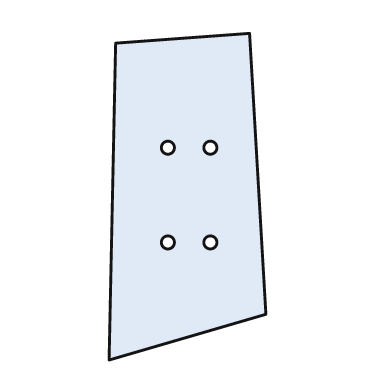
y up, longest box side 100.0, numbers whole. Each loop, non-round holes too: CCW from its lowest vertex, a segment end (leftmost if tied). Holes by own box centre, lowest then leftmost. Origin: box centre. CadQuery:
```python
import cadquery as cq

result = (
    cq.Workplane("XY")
    .moveTo(-24.0, -50.0)
    .lineTo(24.0, -36.0)
    .lineTo(19.0, 50.0)
    .lineTo(-22.0, 47.0)
    .close()
    .moveTo(-6.0, -14.0)
    .circle(2.0)
    .moveTo(7.0, -14.0)
    .circle(2.0)
    .moveTo(-6.0, 15.0)
    .circle(2.0)
    .moveTo(7.0, 15.0)
    .circle(2.0)
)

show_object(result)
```